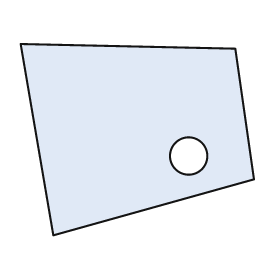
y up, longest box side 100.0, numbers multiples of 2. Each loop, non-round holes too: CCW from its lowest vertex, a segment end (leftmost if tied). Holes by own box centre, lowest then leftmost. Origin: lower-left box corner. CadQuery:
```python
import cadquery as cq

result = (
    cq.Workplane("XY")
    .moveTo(14.0, 0.0)
    .lineTo(100.0, 24.0)
    .lineTo(92.0, 80.0)
    .lineTo(0.0, 82.0)
    .close()
    .moveTo(72.0, 34.0)
    .circle(8.0)
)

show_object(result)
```